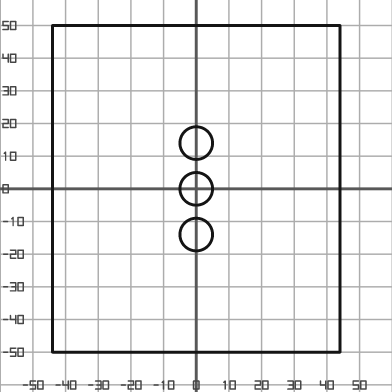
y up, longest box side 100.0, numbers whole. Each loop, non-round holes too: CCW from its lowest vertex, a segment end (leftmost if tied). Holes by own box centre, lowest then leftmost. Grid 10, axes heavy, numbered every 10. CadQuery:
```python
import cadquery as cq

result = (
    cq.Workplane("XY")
    .moveTo(-44.0, -50.0)
    .lineTo(44.0, -50.0)
    .lineTo(44.0, 50.0)
    .lineTo(-44.0, 50.0)
    .close()
    .moveTo(0.0, -14.0)
    .circle(5.0)
    .moveTo(0.0, 0.0)
    .circle(5.0)
    .moveTo(0.0, 14.0)
    .circle(5.0)
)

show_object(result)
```